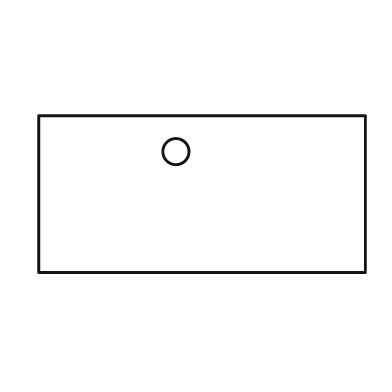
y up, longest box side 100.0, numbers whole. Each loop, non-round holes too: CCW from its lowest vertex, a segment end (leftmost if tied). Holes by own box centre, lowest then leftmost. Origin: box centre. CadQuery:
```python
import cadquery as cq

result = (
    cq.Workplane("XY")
    .moveTo(-50.0, -24.0)
    .lineTo(50.0, -24.0)
    .lineTo(50.0, 24.0)
    .lineTo(-50.0, 24.0)
    .close()
    .moveTo(-8.0, 13.0)
    .circle(4.0)
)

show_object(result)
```